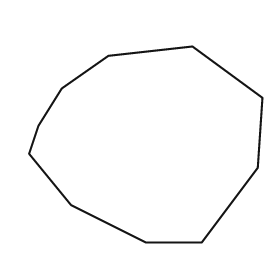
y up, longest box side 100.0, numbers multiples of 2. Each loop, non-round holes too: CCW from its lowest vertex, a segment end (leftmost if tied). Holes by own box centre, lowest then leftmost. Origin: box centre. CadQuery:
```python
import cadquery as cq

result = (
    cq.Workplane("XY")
    .moveTo(0.0, -42.0)
    .lineTo(24.0, -42.0)
    .lineTo(48.0, -10.0)
    .lineTo(50.0, 20.0)
    .lineTo(20.0, 42.0)
    .lineTo(-16.0, 38.0)
    .lineTo(-36.0, 24.0)
    .lineTo(-46.0, 8.0)
    .lineTo(-50.0, -4.0)
    .lineTo(-32.0, -26.0)
    .close()
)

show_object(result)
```